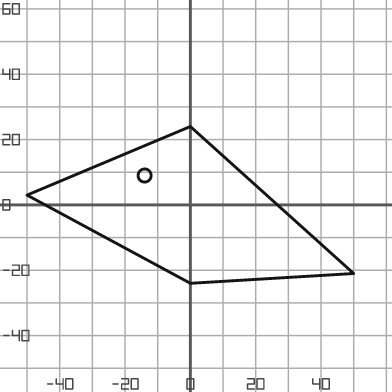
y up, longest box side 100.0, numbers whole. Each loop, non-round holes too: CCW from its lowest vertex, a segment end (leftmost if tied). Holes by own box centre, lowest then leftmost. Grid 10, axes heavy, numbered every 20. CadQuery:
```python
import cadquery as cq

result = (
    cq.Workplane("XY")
    .moveTo(0.0, -24.0)
    .lineTo(50.0, -21.0)
    .lineTo(0.0, 24.0)
    .lineTo(-50.0, 3.0)
    .close()
    .moveTo(-14.0, 9.0)
    .circle(2.0)
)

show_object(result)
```